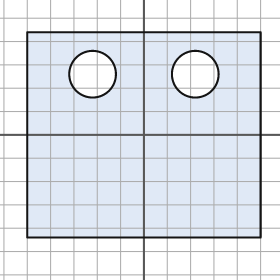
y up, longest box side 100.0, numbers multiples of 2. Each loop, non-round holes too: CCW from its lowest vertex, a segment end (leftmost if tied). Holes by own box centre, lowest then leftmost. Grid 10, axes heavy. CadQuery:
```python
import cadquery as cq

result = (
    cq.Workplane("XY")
    .moveTo(-50.0, -44.0)
    .lineTo(50.0, -44.0)
    .lineTo(50.0, 44.0)
    .lineTo(-50.0, 44.0)
    .close()
    .moveTo(-22.0, 26.0)
    .circle(10.0)
    .moveTo(22.0, 26.0)
    .circle(10.0)
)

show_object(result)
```